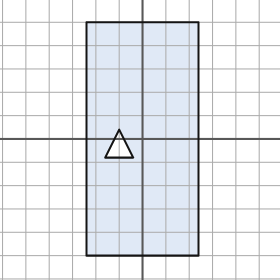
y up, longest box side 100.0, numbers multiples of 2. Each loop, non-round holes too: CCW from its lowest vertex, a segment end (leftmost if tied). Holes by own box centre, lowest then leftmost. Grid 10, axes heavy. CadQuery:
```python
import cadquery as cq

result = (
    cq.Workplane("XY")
    .moveTo(-24.0, -50.0)
    .lineTo(24.0, -50.0)
    .lineTo(24.0, 50.0)
    .lineTo(-24.0, 50.0)
    .close()
    .moveTo(-16.0, -8.0)
    .lineTo(-4.0, -8.0)
    .lineTo(-10.0, 4.0)
    .close()
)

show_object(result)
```